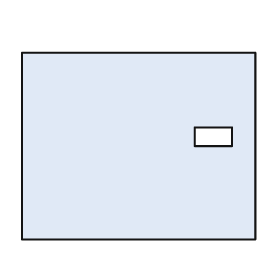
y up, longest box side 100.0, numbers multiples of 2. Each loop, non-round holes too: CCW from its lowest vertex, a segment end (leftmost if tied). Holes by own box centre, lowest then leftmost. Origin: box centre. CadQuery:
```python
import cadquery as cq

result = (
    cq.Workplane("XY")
    .moveTo(-50.0, -40.0)
    .lineTo(50.0, -40.0)
    .lineTo(50.0, 40.0)
    .lineTo(-50.0, 40.0)
    .close()
    .moveTo(24.0, 0.0)
    .lineTo(40.0, 0.0)
    .lineTo(40.0, 8.0)
    .lineTo(24.0, 8.0)
    .close()
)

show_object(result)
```